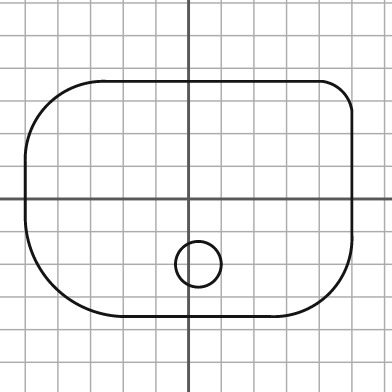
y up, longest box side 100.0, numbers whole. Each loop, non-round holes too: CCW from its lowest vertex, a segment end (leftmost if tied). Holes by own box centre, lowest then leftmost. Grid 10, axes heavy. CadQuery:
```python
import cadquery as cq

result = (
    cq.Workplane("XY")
    .moveTo(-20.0, -36.0)
    .lineTo(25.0, -36.0)
    .threePointArc((43.0, -29.0), (50.0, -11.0))
    .lineTo(50.0, 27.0)
    .threePointArc((47.0, 33.0), (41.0, 36.0))
    .lineTo(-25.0, 36.0)
    .threePointArc((-43.0, 29.0), (-50.0, 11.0))
    .lineTo(-50.0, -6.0)
    .threePointArc((-41.0, -27.0), (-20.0, -36.0))
    .close()
    .moveTo(3.0, -20.0)
    .circle(7.0)
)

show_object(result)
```